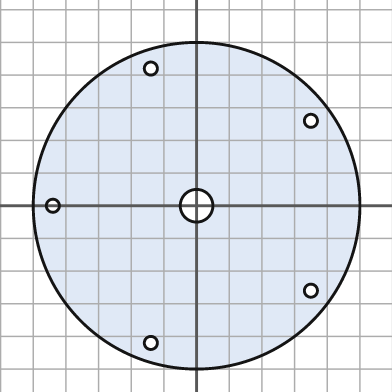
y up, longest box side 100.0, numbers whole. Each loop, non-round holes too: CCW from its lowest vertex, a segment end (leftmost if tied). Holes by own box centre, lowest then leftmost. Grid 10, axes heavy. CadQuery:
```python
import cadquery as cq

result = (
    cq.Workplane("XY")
    .moveTo(0.0, 0.0)
    .circle(50.0)
    .moveTo(-14.0, -42.0)
    .circle(2.0)
    .moveTo(35.0, -26.0)
    .circle(2.0)
    .moveTo(-44.0, 0.0)
    .circle(2.0)
    .moveTo(0.0, 0.0)
    .circle(5.0)
    .moveTo(35.0, 26.0)
    .circle(2.0)
    .moveTo(-14.0, 42.0)
    .circle(2.0)
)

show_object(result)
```